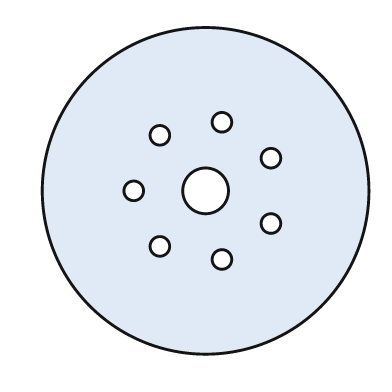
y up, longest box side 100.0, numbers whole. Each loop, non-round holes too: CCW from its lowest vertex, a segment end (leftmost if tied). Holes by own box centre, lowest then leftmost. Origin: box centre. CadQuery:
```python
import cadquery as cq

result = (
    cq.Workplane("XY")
    .moveTo(0.0, 0.0)
    .circle(50.0)
    .moveTo(5.0, -21.0)
    .circle(3.0)
    .moveTo(-14.0, -17.0)
    .circle(3.0)
    .moveTo(20.0, -10.0)
    .circle(3.0)
    .moveTo(-22.0, 0.0)
    .circle(3.0)
    .moveTo(0.0, 0.0)
    .circle(7.0)
    .moveTo(20.0, 10.0)
    .circle(3.0)
    .moveTo(-14.0, 17.0)
    .circle(3.0)
    .moveTo(5.0, 21.0)
    .circle(3.0)
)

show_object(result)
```